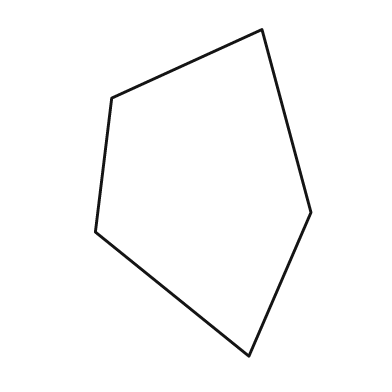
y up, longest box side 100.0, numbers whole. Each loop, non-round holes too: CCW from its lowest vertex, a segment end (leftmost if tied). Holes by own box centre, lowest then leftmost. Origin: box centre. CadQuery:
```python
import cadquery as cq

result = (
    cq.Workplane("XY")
    .moveTo(14.0, -50.0)
    .lineTo(33.0, -6.0)
    .lineTo(18.0, 50.0)
    .lineTo(-28.0, 29.0)
    .lineTo(-33.0, -12.0)
    .close()
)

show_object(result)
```